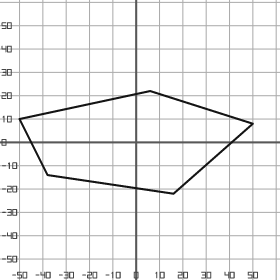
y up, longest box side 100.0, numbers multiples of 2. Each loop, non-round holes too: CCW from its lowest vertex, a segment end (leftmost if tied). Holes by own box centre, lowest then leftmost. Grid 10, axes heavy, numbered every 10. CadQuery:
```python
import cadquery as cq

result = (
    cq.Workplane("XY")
    .moveTo(16.0, -22.0)
    .lineTo(50.0, 8.0)
    .lineTo(6.0, 22.0)
    .lineTo(-50.0, 10.0)
    .lineTo(-38.0, -14.0)
    .close()
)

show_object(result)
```